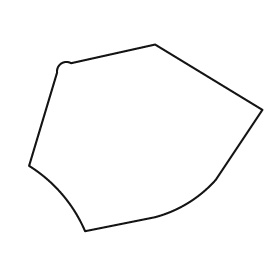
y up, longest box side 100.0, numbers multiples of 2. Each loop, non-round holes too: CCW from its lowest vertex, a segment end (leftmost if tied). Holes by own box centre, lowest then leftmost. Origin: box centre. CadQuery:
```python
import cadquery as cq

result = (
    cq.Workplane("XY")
    .moveTo(-26.0, -40.0)
    .lineTo(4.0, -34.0)
    .threePointArc((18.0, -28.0), (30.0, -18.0))
    .lineTo(50.0, 12.0)
    .lineTo(4.0, 40.0)
    .lineTo(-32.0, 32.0)
    .threePointArc((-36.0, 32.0), (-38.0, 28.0))
    .lineTo(-50.0, -12.0)
    .threePointArc((-36.0, -24.0), (-26.0, -40.0))
    .close()
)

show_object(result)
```